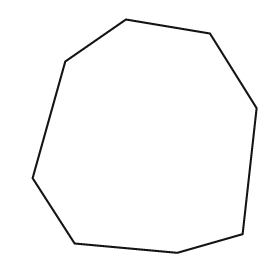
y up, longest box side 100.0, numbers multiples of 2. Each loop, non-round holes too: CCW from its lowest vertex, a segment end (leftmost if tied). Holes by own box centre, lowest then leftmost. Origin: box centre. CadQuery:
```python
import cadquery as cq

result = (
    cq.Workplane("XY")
    .moveTo(14.0, -50.0)
    .lineTo(42.0, -42.0)
    .lineTo(48.0, 12.0)
    .lineTo(28.0, 44.0)
    .lineTo(-8.0, 50.0)
    .lineTo(-34.0, 32.0)
    .lineTo(-48.0, -18.0)
    .lineTo(-30.0, -46.0)
    .close()
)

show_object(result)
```